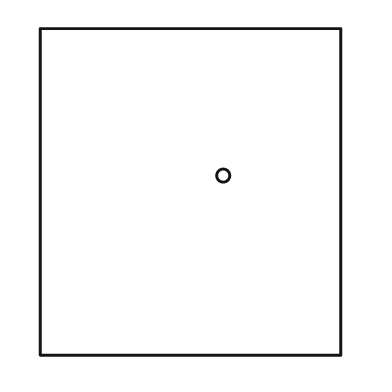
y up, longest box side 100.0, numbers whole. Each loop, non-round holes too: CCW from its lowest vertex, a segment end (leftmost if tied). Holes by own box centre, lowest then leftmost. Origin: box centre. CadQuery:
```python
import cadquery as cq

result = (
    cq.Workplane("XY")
    .moveTo(-46.0, -50.0)
    .lineTo(46.0, -50.0)
    .lineTo(46.0, 50.0)
    .lineTo(-46.0, 50.0)
    .close()
    .moveTo(10.0, 5.0)
    .circle(2.0)
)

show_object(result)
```